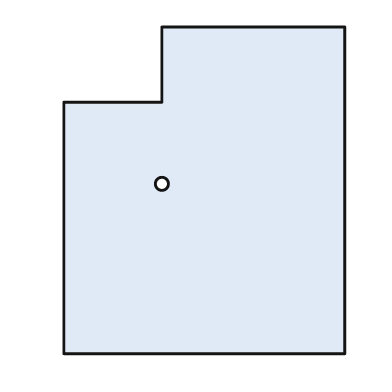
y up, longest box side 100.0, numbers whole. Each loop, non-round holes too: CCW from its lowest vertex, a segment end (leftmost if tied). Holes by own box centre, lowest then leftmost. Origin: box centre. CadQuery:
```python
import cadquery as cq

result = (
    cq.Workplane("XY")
    .moveTo(-43.0, -50.0)
    .lineTo(43.0, -50.0)
    .lineTo(43.0, 50.0)
    .lineTo(-13.0, 50.0)
    .lineTo(-13.0, 27.0)
    .lineTo(-43.0, 27.0)
    .close()
    .moveTo(-13.0, 2.0)
    .circle(2.0)
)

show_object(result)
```